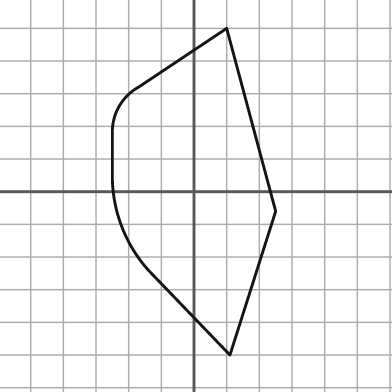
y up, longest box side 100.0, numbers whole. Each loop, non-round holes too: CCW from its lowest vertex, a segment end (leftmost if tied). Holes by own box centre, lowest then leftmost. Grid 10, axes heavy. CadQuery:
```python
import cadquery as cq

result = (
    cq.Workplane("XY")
    .moveTo(11.0, -50.0)
    .lineTo(25.0, -6.0)
    .lineTo(10.0, 50.0)
    .lineTo(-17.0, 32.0)
    .threePointArc((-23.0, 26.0), (-25.0, 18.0))
    .lineTo(-25.0, 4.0)
    .threePointArc((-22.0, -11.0), (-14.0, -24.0))
    .close()
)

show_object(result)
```